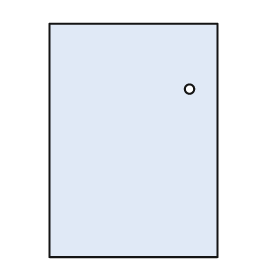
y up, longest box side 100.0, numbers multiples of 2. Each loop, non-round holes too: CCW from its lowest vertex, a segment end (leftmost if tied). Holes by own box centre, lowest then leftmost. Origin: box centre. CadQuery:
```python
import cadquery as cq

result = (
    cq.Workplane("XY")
    .moveTo(-36.0, -50.0)
    .lineTo(36.0, -50.0)
    .lineTo(36.0, 50.0)
    .lineTo(-36.0, 50.0)
    .close()
    .moveTo(24.0, 22.0)
    .circle(2.0)
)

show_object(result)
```